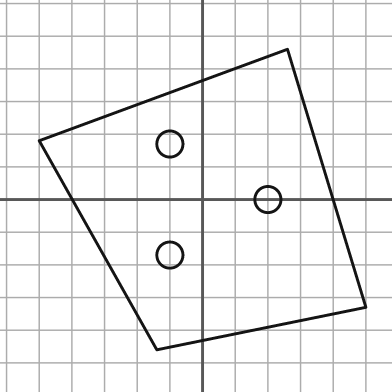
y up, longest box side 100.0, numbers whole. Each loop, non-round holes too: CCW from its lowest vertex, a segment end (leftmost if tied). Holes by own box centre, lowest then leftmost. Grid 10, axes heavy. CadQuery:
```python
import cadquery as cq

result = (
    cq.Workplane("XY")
    .moveTo(-14.0, -46.0)
    .lineTo(50.0, -33.0)
    .lineTo(26.0, 46.0)
    .lineTo(-50.0, 18.0)
    .close()
    .moveTo(-10.0, -17.0)
    .circle(4.0)
    .moveTo(20.0, 0.0)
    .circle(4.0)
    .moveTo(-10.0, 17.0)
    .circle(4.0)
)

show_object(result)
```